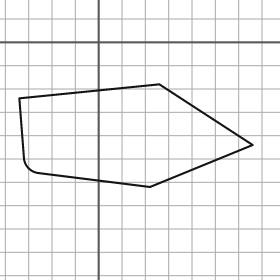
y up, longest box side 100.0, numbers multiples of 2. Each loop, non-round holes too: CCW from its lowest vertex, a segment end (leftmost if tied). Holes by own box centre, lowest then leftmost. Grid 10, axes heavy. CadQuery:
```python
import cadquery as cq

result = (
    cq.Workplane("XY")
    .moveTo(22.0, -62.0)
    .lineTo(66.0, -44.0)
    .lineTo(26.0, -18.0)
    .lineTo(-34.0, -24.0)
    .lineTo(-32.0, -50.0)
    .threePointArc((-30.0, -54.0), (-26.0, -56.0))
    .close()
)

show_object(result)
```